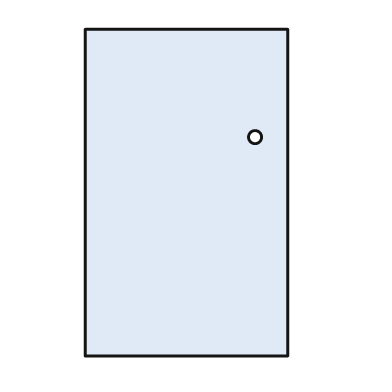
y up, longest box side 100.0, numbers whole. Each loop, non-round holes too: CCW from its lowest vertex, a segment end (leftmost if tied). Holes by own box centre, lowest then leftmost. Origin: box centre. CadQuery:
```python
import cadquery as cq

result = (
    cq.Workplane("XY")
    .moveTo(-31.0, -50.0)
    .lineTo(31.0, -50.0)
    .lineTo(31.0, 50.0)
    .lineTo(-31.0, 50.0)
    .close()
    .moveTo(21.0, 17.0)
    .circle(2.0)
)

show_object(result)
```